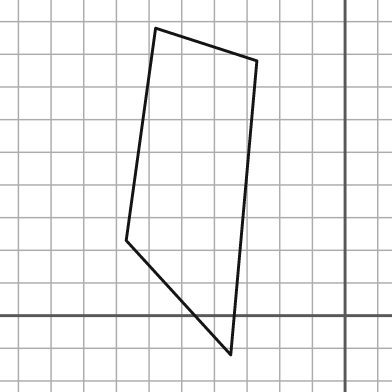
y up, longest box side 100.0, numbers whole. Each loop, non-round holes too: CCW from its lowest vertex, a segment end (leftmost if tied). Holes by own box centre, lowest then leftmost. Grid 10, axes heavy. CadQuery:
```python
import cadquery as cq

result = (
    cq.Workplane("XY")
    .moveTo(-35.0, -12.0)
    .lineTo(-27.0, 78.0)
    .lineTo(-58.0, 88.0)
    .lineTo(-67.0, 23.0)
    .close()
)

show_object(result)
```